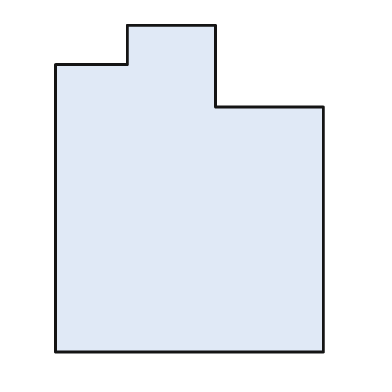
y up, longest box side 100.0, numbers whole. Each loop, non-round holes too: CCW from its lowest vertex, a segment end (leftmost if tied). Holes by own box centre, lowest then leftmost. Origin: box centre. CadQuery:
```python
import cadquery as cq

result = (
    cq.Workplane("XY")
    .moveTo(-41.0, -50.0)
    .lineTo(41.0, -50.0)
    .lineTo(41.0, 25.0)
    .lineTo(8.0, 25.0)
    .lineTo(8.0, 50.0)
    .lineTo(-19.0, 50.0)
    .lineTo(-19.0, 38.0)
    .lineTo(-41.0, 38.0)
    .close()
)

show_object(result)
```